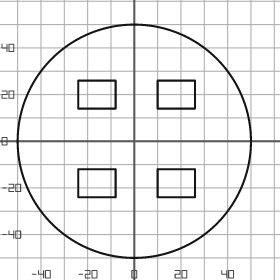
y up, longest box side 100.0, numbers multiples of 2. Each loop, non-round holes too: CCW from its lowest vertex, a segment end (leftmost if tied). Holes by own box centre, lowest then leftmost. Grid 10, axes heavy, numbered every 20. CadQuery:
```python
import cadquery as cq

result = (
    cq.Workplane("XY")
    .moveTo(0.0, 0.0)
    .circle(50.0)
    .moveTo(-24.0, -24.0)
    .lineTo(-8.0, -24.0)
    .lineTo(-8.0, -12.0)
    .lineTo(-24.0, -12.0)
    .close()
    .moveTo(10.0, -24.0)
    .lineTo(26.0, -24.0)
    .lineTo(26.0, -12.0)
    .lineTo(10.0, -12.0)
    .close()
    .moveTo(-24.0, 14.0)
    .lineTo(-8.0, 14.0)
    .lineTo(-8.0, 26.0)
    .lineTo(-24.0, 26.0)
    .close()
    .moveTo(10.0, 14.0)
    .lineTo(26.0, 14.0)
    .lineTo(26.0, 26.0)
    .lineTo(10.0, 26.0)
    .close()
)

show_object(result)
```